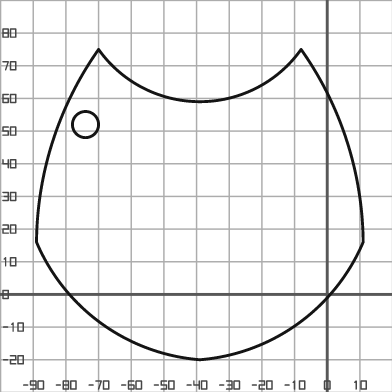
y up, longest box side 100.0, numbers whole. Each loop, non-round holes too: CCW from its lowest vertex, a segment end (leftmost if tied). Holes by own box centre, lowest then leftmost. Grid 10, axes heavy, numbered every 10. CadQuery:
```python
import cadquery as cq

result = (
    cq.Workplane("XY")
    .moveTo(-39.0, -20.0)
    .threePointArc((-9.0, -9.0), (11.0, 16.0))
    .threePointArc((6.0, 47.0), (-8.0, 75.0))
    .threePointArc((-39.0, 59.0), (-70.0, 75.0))
    .threePointArc((-84.0, 47.0), (-89.0, 16.0))
    .threePointArc((-69.0, -9.0), (-39.0, -20.0))
    .close()
    .moveTo(-74.0, 52.0)
    .circle(4.0)
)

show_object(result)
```